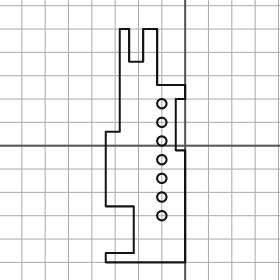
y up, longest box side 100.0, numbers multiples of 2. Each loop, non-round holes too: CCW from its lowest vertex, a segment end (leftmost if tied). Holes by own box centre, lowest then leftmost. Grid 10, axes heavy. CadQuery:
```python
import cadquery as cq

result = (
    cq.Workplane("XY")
    .moveTo(-34.0, -50.0)
    .lineTo(0.0, -50.0)
    .lineTo(0.0, -2.0)
    .lineTo(-4.0, -2.0)
    .lineTo(-4.0, 20.0)
    .lineTo(0.0, 20.0)
    .lineTo(0.0, 26.0)
    .lineTo(-12.0, 26.0)
    .lineTo(-12.0, 50.0)
    .lineTo(-18.0, 50.0)
    .lineTo(-18.0, 36.0)
    .lineTo(-24.0, 36.0)
    .lineTo(-24.0, 50.0)
    .lineTo(-28.0, 50.0)
    .lineTo(-28.0, 6.0)
    .lineTo(-34.0, 6.0)
    .lineTo(-34.0, -26.0)
    .lineTo(-22.0, -26.0)
    .lineTo(-22.0, -46.0)
    .lineTo(-34.0, -46.0)
    .close()
    .moveTo(-10.0, -30.0)
    .circle(2.0)
    .moveTo(-10.0, -22.0)
    .circle(2.0)
    .moveTo(-10.0, -14.0)
    .circle(2.0)
    .moveTo(-10.0, -6.0)
    .circle(2.0)
    .moveTo(-10.0, 2.0)
    .circle(2.0)
    .moveTo(-10.0, 10.0)
    .circle(2.0)
    .moveTo(-10.0, 18.0)
    .circle(2.0)
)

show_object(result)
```